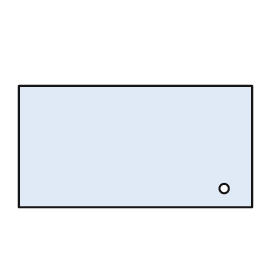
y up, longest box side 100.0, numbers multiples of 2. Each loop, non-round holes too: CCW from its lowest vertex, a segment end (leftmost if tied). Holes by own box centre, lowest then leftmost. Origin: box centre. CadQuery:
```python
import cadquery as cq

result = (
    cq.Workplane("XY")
    .moveTo(-50.0, -26.0)
    .lineTo(50.0, -26.0)
    .lineTo(50.0, 26.0)
    .lineTo(-50.0, 26.0)
    .close()
    .moveTo(38.0, -18.0)
    .circle(2.0)
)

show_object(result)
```